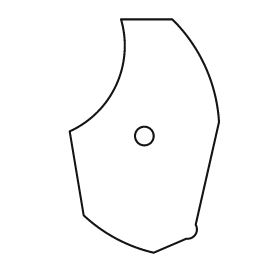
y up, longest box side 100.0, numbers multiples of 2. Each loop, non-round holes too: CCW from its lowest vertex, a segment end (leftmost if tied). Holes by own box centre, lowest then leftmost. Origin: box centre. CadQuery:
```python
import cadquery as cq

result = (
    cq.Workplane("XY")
    .moveTo(4.0, -50.0)
    .lineTo(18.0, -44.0)
    .threePointArc((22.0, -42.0), (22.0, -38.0))
    .lineTo(32.0, 6.0)
    .threePointArc((26.0, 30.0), (12.0, 50.0))
    .lineTo(-10.0, 50.0)
    .threePointArc((-12.0, 22.0), (-32.0, 2.0))
    .lineTo(-26.0, -34.0)
    .threePointArc((-12.0, -44.0), (4.0, -50.0))
    .close()
    .moveTo(0.0, 0.0)
    .circle(4.0)
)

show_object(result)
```